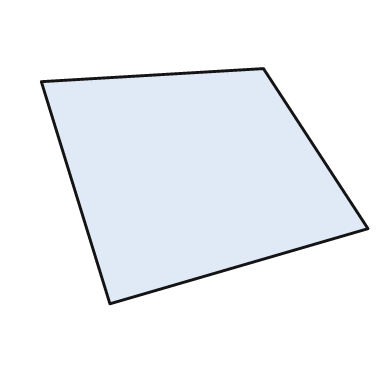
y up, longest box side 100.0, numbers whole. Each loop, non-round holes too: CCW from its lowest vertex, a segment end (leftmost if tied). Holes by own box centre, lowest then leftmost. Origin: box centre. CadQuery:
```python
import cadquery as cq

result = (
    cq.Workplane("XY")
    .moveTo(-29.0, -36.0)
    .lineTo(50.0, -13.0)
    .lineTo(18.0, 36.0)
    .lineTo(-50.0, 32.0)
    .close()
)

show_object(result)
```